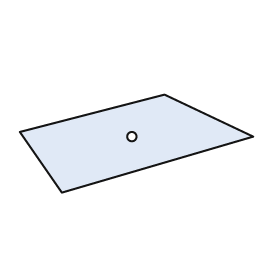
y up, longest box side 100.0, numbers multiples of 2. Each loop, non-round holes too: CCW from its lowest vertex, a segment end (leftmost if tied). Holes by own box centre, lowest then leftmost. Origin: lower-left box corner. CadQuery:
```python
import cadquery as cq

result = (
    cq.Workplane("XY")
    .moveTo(18.0, 0.0)
    .lineTo(100.0, 24.0)
    .lineTo(62.0, 42.0)
    .lineTo(0.0, 26.0)
    .close()
    .moveTo(48.0, 24.0)
    .circle(2.0)
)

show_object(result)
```